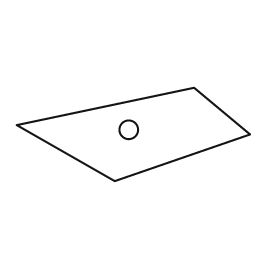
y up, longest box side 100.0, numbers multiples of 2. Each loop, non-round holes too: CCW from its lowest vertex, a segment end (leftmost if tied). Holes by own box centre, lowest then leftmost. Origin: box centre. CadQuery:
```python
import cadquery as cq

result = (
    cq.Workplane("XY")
    .moveTo(-8.0, -20.0)
    .lineTo(50.0, 0.0)
    .lineTo(26.0, 20.0)
    .lineTo(-50.0, 4.0)
    .close()
    .moveTo(-2.0, 2.0)
    .circle(4.0)
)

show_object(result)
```